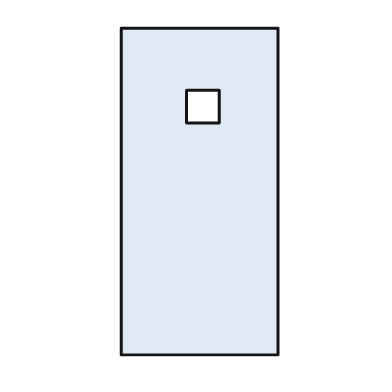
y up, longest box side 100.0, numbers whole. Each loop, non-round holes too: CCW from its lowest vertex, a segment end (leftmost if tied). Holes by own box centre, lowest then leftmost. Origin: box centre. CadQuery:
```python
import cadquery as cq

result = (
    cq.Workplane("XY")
    .moveTo(-24.0, -50.0)
    .lineTo(24.0, -50.0)
    .lineTo(24.0, 50.0)
    .lineTo(-24.0, 50.0)
    .close()
    .moveTo(-4.0, 21.0)
    .lineTo(6.0, 21.0)
    .lineTo(6.0, 31.0)
    .lineTo(-4.0, 31.0)
    .close()
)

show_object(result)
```